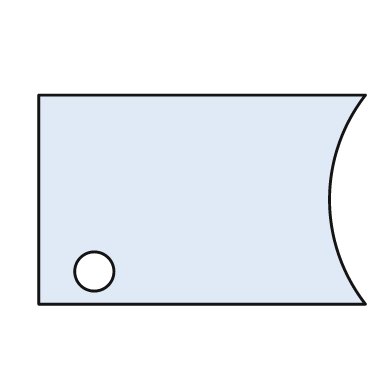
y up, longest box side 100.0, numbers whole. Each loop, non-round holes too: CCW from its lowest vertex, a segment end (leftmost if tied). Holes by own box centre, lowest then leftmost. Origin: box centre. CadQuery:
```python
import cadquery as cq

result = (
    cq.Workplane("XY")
    .moveTo(-50.0, -32.0)
    .lineTo(50.0, -32.0)
    .threePointArc((39.0, 0.0), (50.0, 32.0))
    .lineTo(-50.0, 32.0)
    .close()
    .moveTo(-33.0, -22.0)
    .circle(6.0)
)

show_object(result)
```